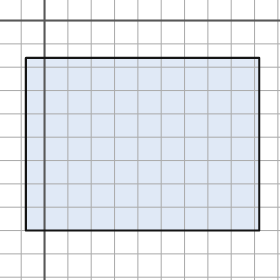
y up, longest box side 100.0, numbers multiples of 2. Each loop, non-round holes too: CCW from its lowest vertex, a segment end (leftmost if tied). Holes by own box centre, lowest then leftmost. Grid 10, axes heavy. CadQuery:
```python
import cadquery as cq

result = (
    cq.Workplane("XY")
    .moveTo(-8.0, -90.0)
    .lineTo(92.0, -90.0)
    .lineTo(92.0, -16.0)
    .lineTo(-8.0, -16.0)
    .close()
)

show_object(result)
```